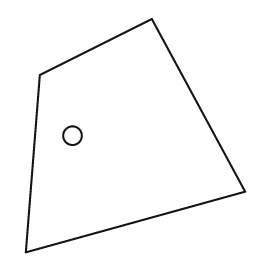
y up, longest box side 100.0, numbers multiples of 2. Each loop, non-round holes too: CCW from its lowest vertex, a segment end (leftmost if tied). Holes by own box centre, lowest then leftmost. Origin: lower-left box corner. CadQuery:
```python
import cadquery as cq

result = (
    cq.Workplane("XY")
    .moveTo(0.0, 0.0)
    .lineTo(94.0, 26.0)
    .lineTo(54.0, 100.0)
    .lineTo(6.0, 76.0)
    .close()
    .moveTo(20.0, 50.0)
    .circle(4.0)
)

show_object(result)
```